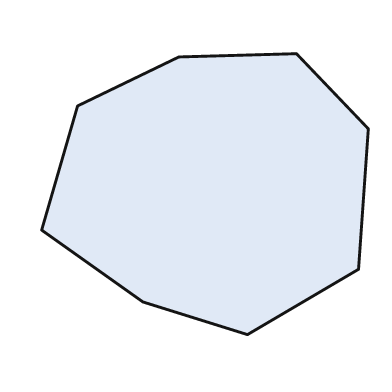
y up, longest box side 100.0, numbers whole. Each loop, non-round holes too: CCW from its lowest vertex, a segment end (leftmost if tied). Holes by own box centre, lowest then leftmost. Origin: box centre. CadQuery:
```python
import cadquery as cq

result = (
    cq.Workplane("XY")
    .moveTo(13.0, -43.0)
    .lineTo(47.0, -23.0)
    .lineTo(50.0, 20.0)
    .lineTo(28.0, 43.0)
    .lineTo(-8.0, 42.0)
    .lineTo(-39.0, 27.0)
    .lineTo(-50.0, -11.0)
    .lineTo(-19.0, -33.0)
    .close()
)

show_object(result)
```